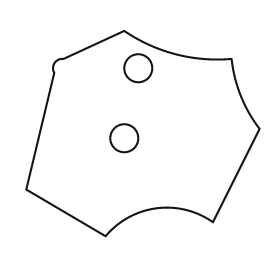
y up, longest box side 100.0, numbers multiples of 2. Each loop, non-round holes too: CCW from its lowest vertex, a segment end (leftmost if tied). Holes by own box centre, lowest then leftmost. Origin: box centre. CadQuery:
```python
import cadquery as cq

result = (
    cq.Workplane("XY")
    .moveTo(-16.0, -44.0)
    .threePointArc((6.0, -32.0), (30.0, -38.0))
    .lineTo(50.0, 2.0)
    .threePointArc((42.0, 16.0), (38.0, 32.0))
    .threePointArc((14.0, 34.0), (-8.0, 44.0))
    .lineTo(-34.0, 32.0)
    .threePointArc((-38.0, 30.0), (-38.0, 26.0))
    .lineTo(-50.0, -24.0)
    .close()
    .moveTo(-8.0, -2.0)
    .circle(6.0)
    .moveTo(-2.0, 28.0)
    .circle(6.0)
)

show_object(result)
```